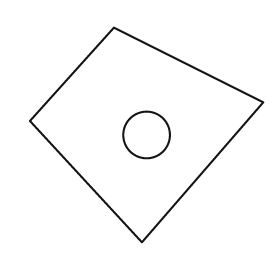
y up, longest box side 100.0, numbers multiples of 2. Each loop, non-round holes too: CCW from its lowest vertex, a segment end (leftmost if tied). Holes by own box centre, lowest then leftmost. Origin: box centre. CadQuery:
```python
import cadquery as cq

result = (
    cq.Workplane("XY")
    .moveTo(-2.0, -46.0)
    .lineTo(50.0, 14.0)
    .lineTo(-14.0, 46.0)
    .lineTo(-50.0, 6.0)
    .close()
    .moveTo(0.0, 0.0)
    .circle(10.0)
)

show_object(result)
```